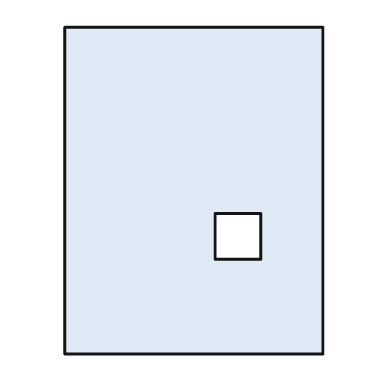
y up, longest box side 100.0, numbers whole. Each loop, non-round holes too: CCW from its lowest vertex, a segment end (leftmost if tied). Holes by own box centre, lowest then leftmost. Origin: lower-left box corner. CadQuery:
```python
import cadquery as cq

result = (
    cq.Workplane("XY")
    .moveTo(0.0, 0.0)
    .lineTo(79.0, 0.0)
    .lineTo(79.0, 100.0)
    .lineTo(0.0, 100.0)
    .close()
    .moveTo(46.0, 29.0)
    .lineTo(60.0, 29.0)
    .lineTo(60.0, 43.0)
    .lineTo(46.0, 43.0)
    .close()
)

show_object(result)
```